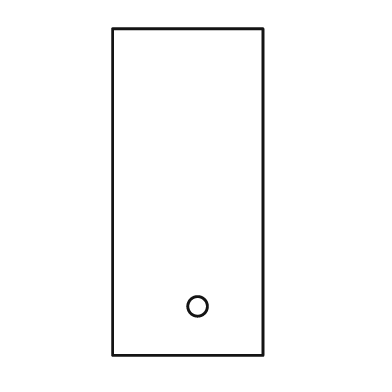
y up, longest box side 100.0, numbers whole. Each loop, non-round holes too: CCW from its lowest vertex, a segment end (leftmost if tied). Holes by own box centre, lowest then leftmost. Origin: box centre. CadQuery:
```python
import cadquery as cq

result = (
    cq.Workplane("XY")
    .moveTo(-23.0, -50.0)
    .lineTo(23.0, -50.0)
    .lineTo(23.0, 50.0)
    .lineTo(-23.0, 50.0)
    .close()
    .moveTo(3.0, -35.0)
    .circle(3.0)
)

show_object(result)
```